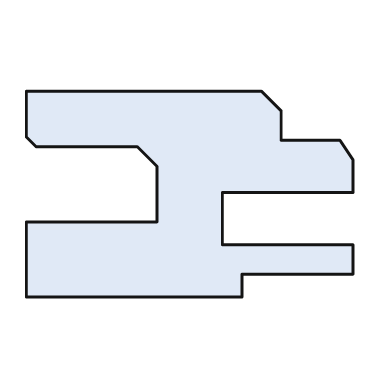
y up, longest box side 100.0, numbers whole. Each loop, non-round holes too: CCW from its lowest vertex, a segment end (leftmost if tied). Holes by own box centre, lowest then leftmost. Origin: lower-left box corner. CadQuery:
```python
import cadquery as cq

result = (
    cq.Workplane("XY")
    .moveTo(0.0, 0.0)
    .lineTo(66.0, 0.0)
    .lineTo(66.0, 7.0)
    .lineTo(100.0, 7.0)
    .lineTo(100.0, 16.0)
    .lineTo(60.0, 16.0)
    .lineTo(60.0, 32.0)
    .lineTo(100.0, 32.0)
    .lineTo(100.0, 42.0)
    .lineTo(96.0, 48.0)
    .lineTo(78.0, 48.0)
    .lineTo(78.0, 57.0)
    .lineTo(72.0, 63.0)
    .lineTo(0.0, 63.0)
    .lineTo(0.0, 49.0)
    .lineTo(3.0, 46.0)
    .lineTo(34.0, 46.0)
    .lineTo(40.0, 40.0)
    .lineTo(40.0, 23.0)
    .lineTo(0.0, 23.0)
    .close()
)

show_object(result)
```